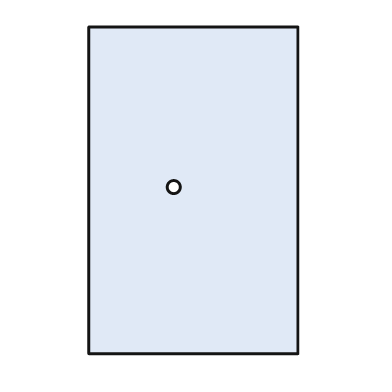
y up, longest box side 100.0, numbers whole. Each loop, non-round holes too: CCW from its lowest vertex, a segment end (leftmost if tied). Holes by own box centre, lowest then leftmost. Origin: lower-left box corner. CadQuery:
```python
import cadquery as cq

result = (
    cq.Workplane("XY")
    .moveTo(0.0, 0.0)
    .lineTo(64.0, 0.0)
    .lineTo(64.0, 100.0)
    .lineTo(0.0, 100.0)
    .close()
    .moveTo(26.0, 51.0)
    .circle(2.0)
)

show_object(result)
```